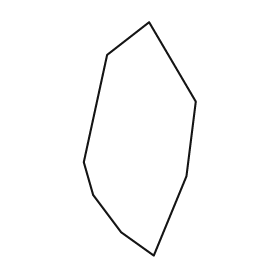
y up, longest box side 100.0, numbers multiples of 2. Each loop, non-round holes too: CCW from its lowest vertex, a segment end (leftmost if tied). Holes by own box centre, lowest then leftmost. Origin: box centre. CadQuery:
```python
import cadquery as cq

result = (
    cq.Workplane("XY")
    .moveTo(6.0, -50.0)
    .lineTo(20.0, -16.0)
    .lineTo(24.0, 16.0)
    .lineTo(4.0, 50.0)
    .lineTo(-14.0, 36.0)
    .lineTo(-24.0, -10.0)
    .lineTo(-20.0, -24.0)
    .lineTo(-8.0, -40.0)
    .close()
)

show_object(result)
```